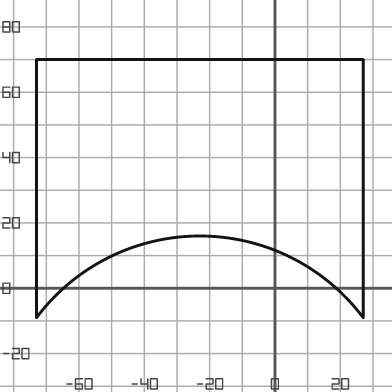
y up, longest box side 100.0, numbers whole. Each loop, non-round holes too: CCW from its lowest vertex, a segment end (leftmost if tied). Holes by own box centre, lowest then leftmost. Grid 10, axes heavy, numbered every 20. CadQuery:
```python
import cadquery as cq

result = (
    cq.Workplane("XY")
    .moveTo(-73.0, -9.0)
    .threePointArc((-23.0, 16.0), (27.0, -9.0))
    .lineTo(27.0, 70.0)
    .lineTo(-73.0, 70.0)
    .close()
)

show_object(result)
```